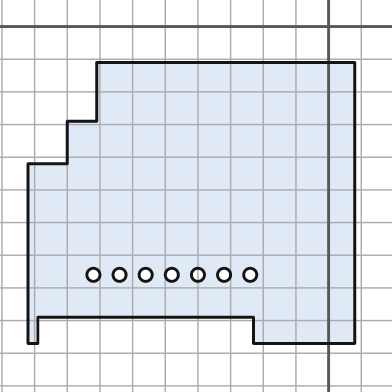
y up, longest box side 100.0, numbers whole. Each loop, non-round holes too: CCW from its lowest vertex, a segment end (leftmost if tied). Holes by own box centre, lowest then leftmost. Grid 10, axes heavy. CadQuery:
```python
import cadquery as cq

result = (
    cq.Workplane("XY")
    .moveTo(-92.0, -97.0)
    .lineTo(-89.0, -97.0)
    .lineTo(-89.0, -89.0)
    .lineTo(-23.0, -89.0)
    .lineTo(-23.0, -97.0)
    .lineTo(8.0, -97.0)
    .lineTo(8.0, -11.0)
    .lineTo(-71.0, -11.0)
    .lineTo(-71.0, -29.0)
    .lineTo(-80.0, -29.0)
    .lineTo(-80.0, -42.0)
    .lineTo(-92.0, -42.0)
    .close()
    .moveTo(-72.0, -76.0)
    .circle(2.0)
    .moveTo(-64.0, -76.0)
    .circle(2.0)
    .moveTo(-56.0, -76.0)
    .circle(2.0)
    .moveTo(-48.0, -76.0)
    .circle(2.0)
    .moveTo(-40.0, -76.0)
    .circle(2.0)
    .moveTo(-32.0, -76.0)
    .circle(2.0)
    .moveTo(-24.0, -76.0)
    .circle(2.0)
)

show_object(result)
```